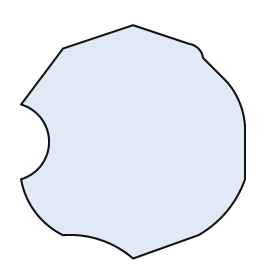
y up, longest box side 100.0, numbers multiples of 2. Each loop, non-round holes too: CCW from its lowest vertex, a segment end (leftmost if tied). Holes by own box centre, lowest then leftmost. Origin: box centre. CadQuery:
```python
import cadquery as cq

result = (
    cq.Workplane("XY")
    .moveTo(0.0, -50.0)
    .lineTo(28.0, -40.0)
    .threePointArc((40.0, -30.0), (48.0, -16.0))
    .lineTo(48.0, 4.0)
    .threePointArc((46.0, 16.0), (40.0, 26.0))
    .lineTo(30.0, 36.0)
    .threePointArc((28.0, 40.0), (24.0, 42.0))
    .lineTo(0.0, 50.0)
    .lineTo(-30.0, 40.0)
    .lineTo(-48.0, 16.0)
    .threePointArc((-36.0, 0.0), (-48.0, -16.0))
    .threePointArc((-42.0, -30.0), (-30.0, -40.0))
    .threePointArc((-14.0, -42.0), (0.0, -50.0))
    .close()
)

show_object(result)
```